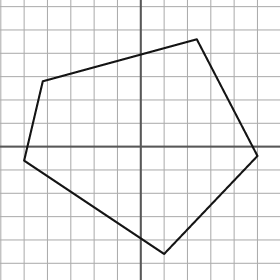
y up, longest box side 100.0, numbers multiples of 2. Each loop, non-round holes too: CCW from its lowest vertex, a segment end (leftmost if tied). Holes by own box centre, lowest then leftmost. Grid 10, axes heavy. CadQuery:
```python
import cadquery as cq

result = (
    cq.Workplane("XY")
    .moveTo(10.0, -46.0)
    .lineTo(50.0, -4.0)
    .lineTo(24.0, 46.0)
    .lineTo(-42.0, 28.0)
    .lineTo(-50.0, -6.0)
    .close()
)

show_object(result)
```